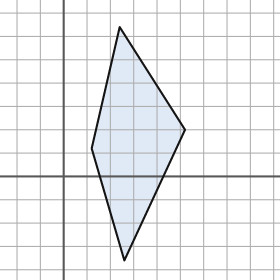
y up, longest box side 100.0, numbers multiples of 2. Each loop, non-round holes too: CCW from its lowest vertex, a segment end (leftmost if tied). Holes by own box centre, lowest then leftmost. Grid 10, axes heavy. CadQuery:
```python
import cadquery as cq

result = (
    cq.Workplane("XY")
    .moveTo(26.0, -36.0)
    .lineTo(52.0, 20.0)
    .lineTo(24.0, 64.0)
    .lineTo(12.0, 12.0)
    .close()
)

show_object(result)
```